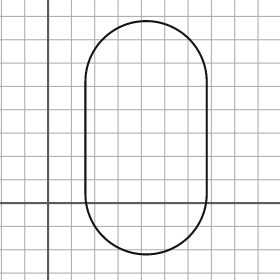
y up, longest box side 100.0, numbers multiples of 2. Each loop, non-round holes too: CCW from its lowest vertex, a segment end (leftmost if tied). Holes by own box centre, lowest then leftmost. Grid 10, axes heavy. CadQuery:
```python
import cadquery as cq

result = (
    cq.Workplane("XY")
    .moveTo(16.0, 4.0)
    .threePointArc((42.0, -22.0), (68.0, 4.0))
    .lineTo(68.0, 52.0)
    .threePointArc((42.0, 78.0), (16.0, 52.0))
    .close()
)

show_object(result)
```